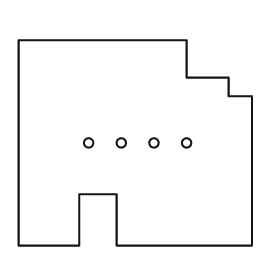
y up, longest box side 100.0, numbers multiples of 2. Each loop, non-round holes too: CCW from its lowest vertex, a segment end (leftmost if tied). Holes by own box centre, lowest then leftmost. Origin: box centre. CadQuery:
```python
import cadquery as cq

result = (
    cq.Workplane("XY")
    .moveTo(-50.0, -44.0)
    .lineTo(-24.0, -44.0)
    .lineTo(-24.0, -22.0)
    .lineTo(-8.0, -22.0)
    .lineTo(-8.0, -44.0)
    .lineTo(50.0, -44.0)
    .lineTo(50.0, 20.0)
    .lineTo(40.0, 20.0)
    .lineTo(40.0, 28.0)
    .lineTo(22.0, 28.0)
    .lineTo(22.0, 44.0)
    .lineTo(-50.0, 44.0)
    .close()
    .moveTo(-20.0, 0.0)
    .circle(2.0)
    .moveTo(-6.0, 0.0)
    .circle(2.0)
    .moveTo(8.0, 0.0)
    .circle(2.0)
    .moveTo(22.0, 0.0)
    .circle(2.0)
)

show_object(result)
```